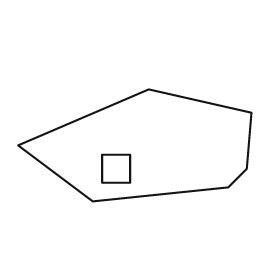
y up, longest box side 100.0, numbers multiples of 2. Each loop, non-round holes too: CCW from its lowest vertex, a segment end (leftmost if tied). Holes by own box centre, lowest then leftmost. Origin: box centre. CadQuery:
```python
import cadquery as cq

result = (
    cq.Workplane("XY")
    .moveTo(-18.0, -24.0)
    .lineTo(40.0, -18.0)
    .lineTo(48.0, -10.0)
    .lineTo(50.0, 14.0)
    .lineTo(6.0, 24.0)
    .lineTo(-50.0, 0.0)
    .close()
    .moveTo(-14.0, -16.0)
    .lineTo(-2.0, -16.0)
    .lineTo(-2.0, -4.0)
    .lineTo(-14.0, -4.0)
    .close()
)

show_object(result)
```